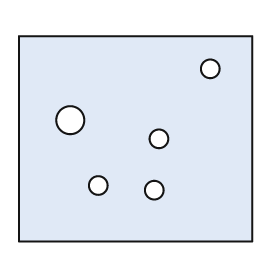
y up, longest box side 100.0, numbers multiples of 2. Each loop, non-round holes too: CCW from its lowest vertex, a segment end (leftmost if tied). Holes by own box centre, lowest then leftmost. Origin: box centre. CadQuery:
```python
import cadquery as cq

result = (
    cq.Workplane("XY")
    .moveTo(-50.0, -44.0)
    .lineTo(50.0, -44.0)
    .lineTo(50.0, 44.0)
    .lineTo(-50.0, 44.0)
    .close()
    .moveTo(8.0, -22.0)
    .circle(4.0)
    .moveTo(-16.0, -20.0)
    .circle(4.0)
    .moveTo(10.0, 0.0)
    .circle(4.0)
    .moveTo(-28.0, 8.0)
    .circle(6.0)
    .moveTo(32.0, 30.0)
    .circle(4.0)
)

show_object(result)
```